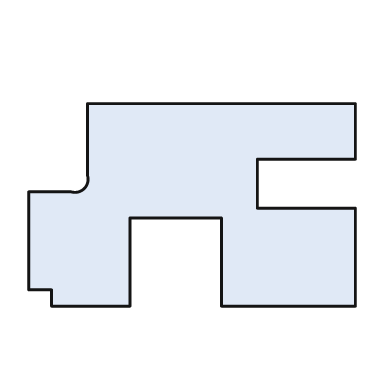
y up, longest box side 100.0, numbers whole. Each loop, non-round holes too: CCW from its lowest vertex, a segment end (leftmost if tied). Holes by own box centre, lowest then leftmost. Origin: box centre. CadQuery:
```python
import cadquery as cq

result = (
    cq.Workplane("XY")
    .moveTo(-43.0, -31.0)
    .lineTo(-19.0, -31.0)
    .lineTo(-19.0, -4.0)
    .lineTo(9.0, -4.0)
    .lineTo(9.0, -31.0)
    .lineTo(50.0, -31.0)
    .lineTo(50.0, -1.0)
    .lineTo(20.0, -1.0)
    .lineTo(20.0, 14.0)
    .lineTo(50.0, 14.0)
    .lineTo(50.0, 31.0)
    .lineTo(-32.0, 31.0)
    .lineTo(-32.0, 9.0)
    .threePointArc((-33.0, 5.0), (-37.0, 4.0))
    .lineTo(-50.0, 4.0)
    .lineTo(-50.0, -26.0)
    .lineTo(-43.0, -26.0)
    .close()
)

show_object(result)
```